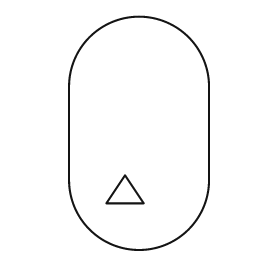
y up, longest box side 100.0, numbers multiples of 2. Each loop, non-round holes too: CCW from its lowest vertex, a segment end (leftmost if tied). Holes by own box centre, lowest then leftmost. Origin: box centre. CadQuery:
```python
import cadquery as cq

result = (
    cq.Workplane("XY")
    .moveTo(-30.0, -20.0)
    .threePointArc((0.0, -50.0), (30.0, -20.0))
    .lineTo(30.0, 20.0)
    .threePointArc((0.0, 50.0), (-30.0, 20.0))
    .close()
    .moveTo(-14.0, -30.0)
    .lineTo(2.0, -30.0)
    .lineTo(-6.0, -18.0)
    .close()
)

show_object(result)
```